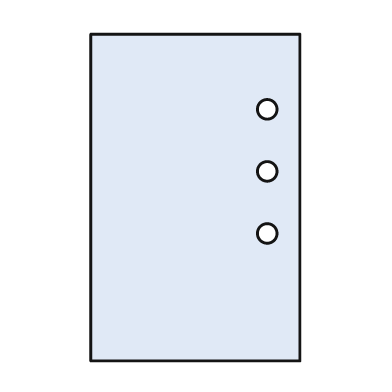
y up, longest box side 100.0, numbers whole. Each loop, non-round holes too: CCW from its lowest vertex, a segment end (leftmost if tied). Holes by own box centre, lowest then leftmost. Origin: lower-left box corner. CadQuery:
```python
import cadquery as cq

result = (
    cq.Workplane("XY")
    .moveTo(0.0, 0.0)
    .lineTo(64.0, 0.0)
    .lineTo(64.0, 100.0)
    .lineTo(0.0, 100.0)
    .close()
    .moveTo(54.0, 39.0)
    .circle(3.0)
    .moveTo(54.0, 58.0)
    .circle(3.0)
    .moveTo(54.0, 77.0)
    .circle(3.0)
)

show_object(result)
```